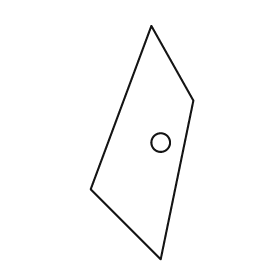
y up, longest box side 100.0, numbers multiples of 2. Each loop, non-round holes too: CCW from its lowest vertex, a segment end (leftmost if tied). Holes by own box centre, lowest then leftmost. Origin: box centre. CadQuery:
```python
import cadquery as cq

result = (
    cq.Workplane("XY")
    .moveTo(8.0, -50.0)
    .lineTo(22.0, 18.0)
    .lineTo(4.0, 50.0)
    .lineTo(-22.0, -20.0)
    .close()
    .moveTo(8.0, 0.0)
    .circle(4.0)
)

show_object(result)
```